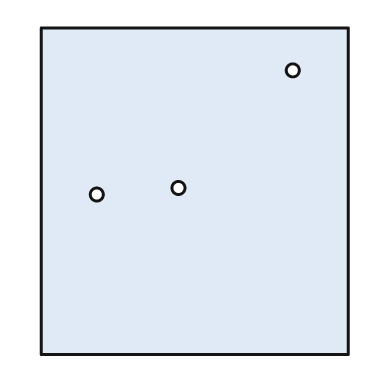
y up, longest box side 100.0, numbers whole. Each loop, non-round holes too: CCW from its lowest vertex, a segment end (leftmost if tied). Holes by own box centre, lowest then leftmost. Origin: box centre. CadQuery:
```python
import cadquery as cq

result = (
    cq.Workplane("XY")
    .moveTo(-47.0, -50.0)
    .lineTo(47.0, -50.0)
    .lineTo(47.0, 50.0)
    .lineTo(-47.0, 50.0)
    .close()
    .moveTo(-30.0, -1.0)
    .circle(2.0)
    .moveTo(-5.0, 1.0)
    .circle(2.0)
    .moveTo(30.0, 37.0)
    .circle(2.0)
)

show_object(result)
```